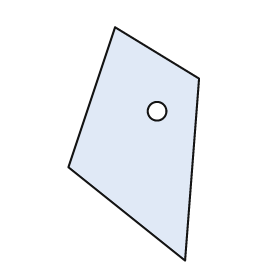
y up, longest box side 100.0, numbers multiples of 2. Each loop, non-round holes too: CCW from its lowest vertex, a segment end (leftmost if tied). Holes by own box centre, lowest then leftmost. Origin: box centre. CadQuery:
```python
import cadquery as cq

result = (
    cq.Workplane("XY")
    .moveTo(22.0, -50.0)
    .lineTo(28.0, 28.0)
    .lineTo(-8.0, 50.0)
    .lineTo(-28.0, -10.0)
    .close()
    .moveTo(10.0, 14.0)
    .circle(4.0)
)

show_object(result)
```